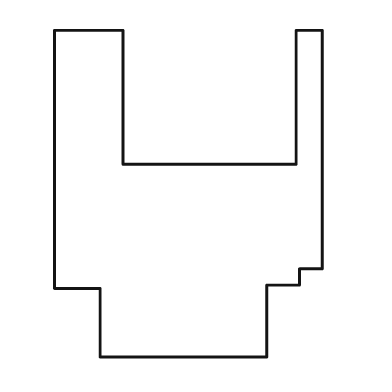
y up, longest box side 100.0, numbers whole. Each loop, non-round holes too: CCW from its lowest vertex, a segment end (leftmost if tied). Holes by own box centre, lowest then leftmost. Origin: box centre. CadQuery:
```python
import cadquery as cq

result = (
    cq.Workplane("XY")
    .moveTo(-27.0, -50.0)
    .lineTo(24.0, -50.0)
    .lineTo(24.0, -28.0)
    .lineTo(34.0, -28.0)
    .lineTo(34.0, -23.0)
    .lineTo(41.0, -23.0)
    .lineTo(41.0, 50.0)
    .lineTo(33.0, 50.0)
    .lineTo(33.0, 9.0)
    .lineTo(-20.0, 9.0)
    .lineTo(-20.0, 50.0)
    .lineTo(-41.0, 50.0)
    .lineTo(-41.0, -29.0)
    .lineTo(-27.0, -29.0)
    .close()
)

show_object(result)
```